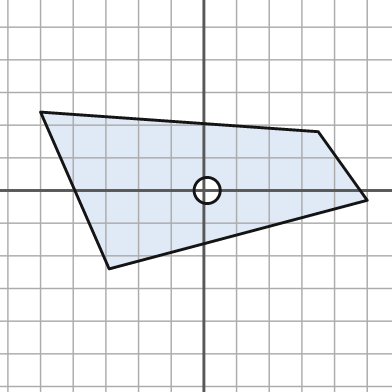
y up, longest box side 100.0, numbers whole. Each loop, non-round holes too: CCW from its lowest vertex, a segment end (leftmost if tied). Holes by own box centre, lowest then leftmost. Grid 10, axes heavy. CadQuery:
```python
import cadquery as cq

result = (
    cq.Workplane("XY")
    .moveTo(-29.0, -24.0)
    .lineTo(50.0, -3.0)
    .lineTo(35.0, 18.0)
    .lineTo(-50.0, 24.0)
    .close()
    .moveTo(1.0, 0.0)
    .circle(4.0)
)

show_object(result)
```